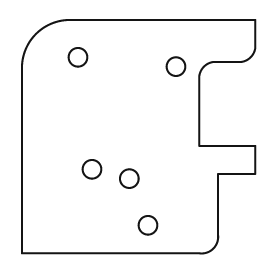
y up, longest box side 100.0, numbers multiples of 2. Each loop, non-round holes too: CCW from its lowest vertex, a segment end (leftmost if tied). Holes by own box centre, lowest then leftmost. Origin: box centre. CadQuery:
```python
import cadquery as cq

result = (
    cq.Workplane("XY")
    .moveTo(-50.0, -50.0)
    .lineTo(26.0, -50.0)
    .threePointArc((32.0, -48.0), (34.0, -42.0))
    .lineTo(34.0, -16.0)
    .lineTo(50.0, -16.0)
    .lineTo(50.0, -4.0)
    .lineTo(26.0, -4.0)
    .lineTo(26.0, 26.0)
    .threePointArc((28.0, 30.0), (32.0, 32.0))
    .lineTo(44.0, 32.0)
    .threePointArc((48.0, 34.0), (50.0, 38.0))
    .lineTo(50.0, 50.0)
    .lineTo(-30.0, 50.0)
    .threePointArc((-44.0, 44.0), (-50.0, 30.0))
    .close()
    .moveTo(4.0, -38.0)
    .circle(4.0)
    .moveTo(-4.0, -18.0)
    .circle(4.0)
    .moveTo(-20.0, -14.0)
    .circle(4.0)
    .moveTo(16.0, 30.0)
    .circle(4.0)
    .moveTo(-26.0, 34.0)
    .circle(4.0)
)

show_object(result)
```